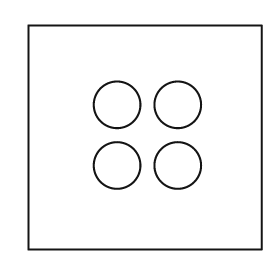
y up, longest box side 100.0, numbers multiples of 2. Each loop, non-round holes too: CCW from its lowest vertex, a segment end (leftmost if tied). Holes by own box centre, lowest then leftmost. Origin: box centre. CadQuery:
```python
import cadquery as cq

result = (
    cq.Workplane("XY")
    .moveTo(-50.0, -48.0)
    .lineTo(50.0, -48.0)
    .lineTo(50.0, 48.0)
    .lineTo(-50.0, 48.0)
    .close()
    .moveTo(-12.0, -12.0)
    .circle(10.0)
    .moveTo(14.0, -12.0)
    .circle(10.0)
    .moveTo(-12.0, 14.0)
    .circle(10.0)
    .moveTo(14.0, 14.0)
    .circle(10.0)
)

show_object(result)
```